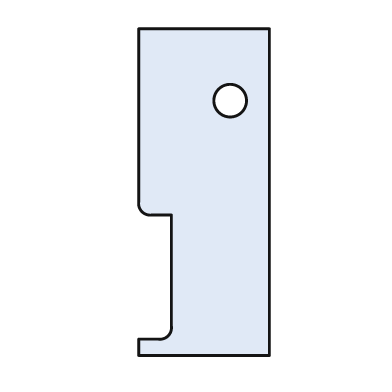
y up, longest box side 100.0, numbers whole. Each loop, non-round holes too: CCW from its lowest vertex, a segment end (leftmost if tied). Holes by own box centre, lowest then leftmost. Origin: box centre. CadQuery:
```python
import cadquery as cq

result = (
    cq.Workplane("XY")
    .moveTo(-20.0, -50.0)
    .lineTo(20.0, -50.0)
    .lineTo(20.0, 50.0)
    .lineTo(-20.0, 50.0)
    .lineTo(-20.0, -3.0)
    .threePointArc((-19.0, -6.0), (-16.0, -7.0))
    .lineTo(-10.0, -7.0)
    .lineTo(-10.0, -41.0)
    .threePointArc((-11.0, -44.0), (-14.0, -45.0))
    .lineTo(-20.0, -45.0)
    .close()
    .moveTo(8.0, 28.0)
    .circle(5.0)
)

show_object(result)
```